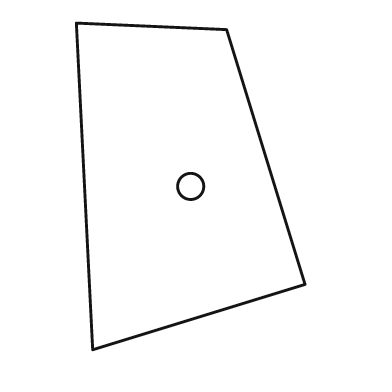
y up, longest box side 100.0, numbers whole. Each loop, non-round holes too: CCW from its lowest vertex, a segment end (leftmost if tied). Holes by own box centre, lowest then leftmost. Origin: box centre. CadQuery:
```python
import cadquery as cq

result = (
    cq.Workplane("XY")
    .moveTo(-30.0, -50.0)
    .lineTo(35.0, -30.0)
    .lineTo(11.0, 48.0)
    .lineTo(-35.0, 50.0)
    .close()
    .moveTo(0.0, 0.0)
    .circle(4.0)
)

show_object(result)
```